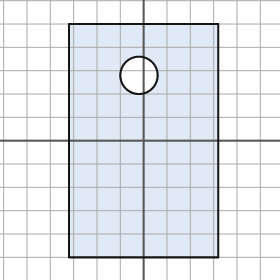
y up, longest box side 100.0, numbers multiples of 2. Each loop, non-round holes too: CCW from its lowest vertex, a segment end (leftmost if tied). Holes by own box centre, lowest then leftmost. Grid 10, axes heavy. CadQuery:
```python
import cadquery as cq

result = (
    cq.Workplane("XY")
    .moveTo(-32.0, -50.0)
    .lineTo(32.0, -50.0)
    .lineTo(32.0, 50.0)
    .lineTo(-32.0, 50.0)
    .close()
    .moveTo(-2.0, 28.0)
    .circle(8.0)
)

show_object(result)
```